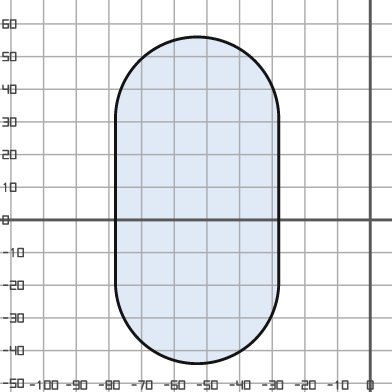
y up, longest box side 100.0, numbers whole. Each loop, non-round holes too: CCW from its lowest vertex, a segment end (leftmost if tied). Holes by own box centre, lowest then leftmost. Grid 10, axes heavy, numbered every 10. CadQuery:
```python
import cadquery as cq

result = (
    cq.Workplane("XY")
    .moveTo(-78.0, -19.0)
    .threePointArc((-53.0, -44.0), (-28.0, -19.0))
    .lineTo(-28.0, 31.0)
    .threePointArc((-53.0, 56.0), (-78.0, 31.0))
    .close()
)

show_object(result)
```